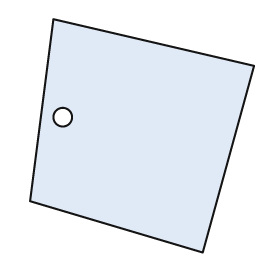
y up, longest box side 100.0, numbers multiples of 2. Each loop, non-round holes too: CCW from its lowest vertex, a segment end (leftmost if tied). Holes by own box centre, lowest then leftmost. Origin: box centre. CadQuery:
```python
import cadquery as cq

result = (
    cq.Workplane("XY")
    .moveTo(26.0, -50.0)
    .lineTo(48.0, 30.0)
    .lineTo(-38.0, 50.0)
    .lineTo(-48.0, -28.0)
    .close()
    .moveTo(-34.0, 8.0)
    .circle(4.0)
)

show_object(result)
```